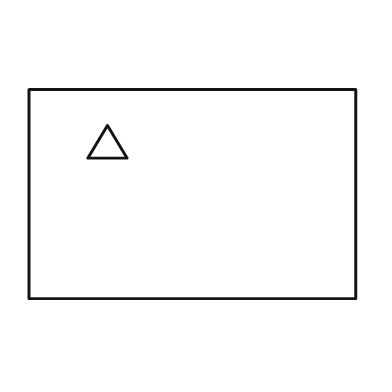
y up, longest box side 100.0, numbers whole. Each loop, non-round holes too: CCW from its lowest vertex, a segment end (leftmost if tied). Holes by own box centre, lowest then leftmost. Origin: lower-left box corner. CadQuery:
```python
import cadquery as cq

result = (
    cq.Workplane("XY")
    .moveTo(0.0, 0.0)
    .lineTo(100.0, 0.0)
    .lineTo(100.0, 64.0)
    .lineTo(0.0, 64.0)
    .close()
    .moveTo(18.0, 43.0)
    .lineTo(30.0, 43.0)
    .lineTo(24.0, 53.0)
    .close()
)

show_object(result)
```